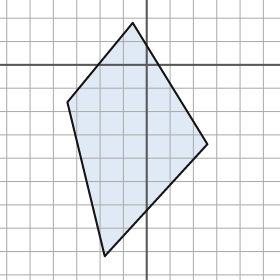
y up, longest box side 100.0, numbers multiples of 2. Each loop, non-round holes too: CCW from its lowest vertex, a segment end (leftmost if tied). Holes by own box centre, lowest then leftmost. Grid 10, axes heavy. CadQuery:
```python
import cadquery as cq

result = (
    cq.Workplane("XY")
    .moveTo(-18.0, -82.0)
    .lineTo(26.0, -34.0)
    .lineTo(-6.0, 18.0)
    .lineTo(-34.0, -16.0)
    .close()
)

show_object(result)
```